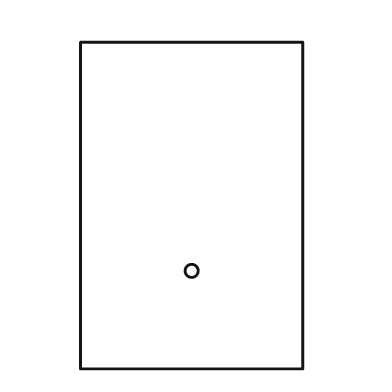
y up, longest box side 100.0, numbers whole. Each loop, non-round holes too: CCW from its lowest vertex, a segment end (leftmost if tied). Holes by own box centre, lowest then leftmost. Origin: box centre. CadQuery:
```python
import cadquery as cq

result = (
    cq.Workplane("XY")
    .moveTo(-34.0, -50.0)
    .lineTo(34.0, -50.0)
    .lineTo(34.0, 50.0)
    .lineTo(-34.0, 50.0)
    .close()
    .moveTo(0.0, -20.0)
    .circle(2.0)
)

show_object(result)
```